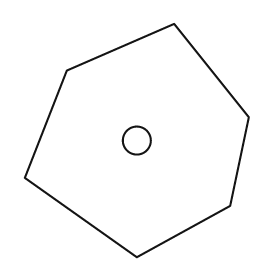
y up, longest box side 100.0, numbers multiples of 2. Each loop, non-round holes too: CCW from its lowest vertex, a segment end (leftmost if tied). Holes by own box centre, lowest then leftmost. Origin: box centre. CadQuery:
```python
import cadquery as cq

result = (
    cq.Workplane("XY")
    .moveTo(0.0, -50.0)
    .lineTo(40.0, -28.0)
    .lineTo(48.0, 10.0)
    .lineTo(16.0, 50.0)
    .lineTo(-30.0, 30.0)
    .lineTo(-48.0, -16.0)
    .close()
    .moveTo(0.0, 0.0)
    .circle(6.0)
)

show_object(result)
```